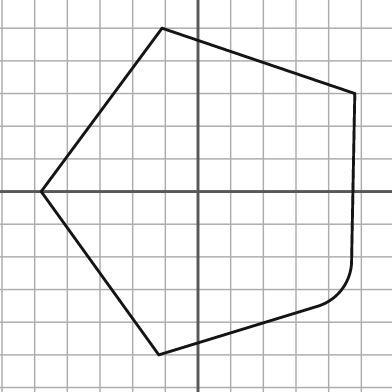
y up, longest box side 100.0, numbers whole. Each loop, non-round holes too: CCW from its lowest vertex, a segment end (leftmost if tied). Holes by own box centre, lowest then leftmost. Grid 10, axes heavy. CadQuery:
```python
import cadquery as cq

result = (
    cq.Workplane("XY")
    .moveTo(-12.0, -50.0)
    .lineTo(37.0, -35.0)
    .threePointArc((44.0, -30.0), (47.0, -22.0))
    .lineTo(48.0, 30.0)
    .lineTo(-11.0, 50.0)
    .lineTo(-48.0, 0.0)
    .close()
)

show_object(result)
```